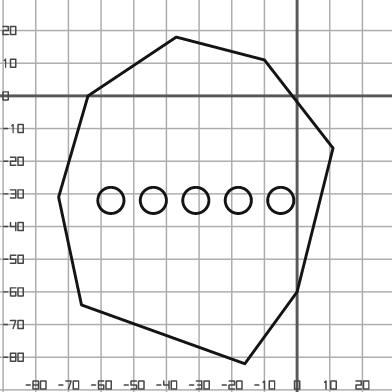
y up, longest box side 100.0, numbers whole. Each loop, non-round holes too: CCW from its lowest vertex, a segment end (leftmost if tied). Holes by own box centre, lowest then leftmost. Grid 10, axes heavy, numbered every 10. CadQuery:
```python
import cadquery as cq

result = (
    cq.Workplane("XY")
    .moveTo(-16.0, -82.0)
    .lineTo(0.0, -60.0)
    .lineTo(11.0, -16.0)
    .lineTo(-10.0, 11.0)
    .lineTo(-37.0, 18.0)
    .lineTo(-64.0, 0.0)
    .lineTo(-73.0, -31.0)
    .lineTo(-66.0, -64.0)
    .close()
    .moveTo(-57.0, -32.0)
    .circle(4.0)
    .moveTo(-44.0, -32.0)
    .circle(4.0)
    .moveTo(-31.0, -32.0)
    .circle(4.0)
    .moveTo(-18.0, -32.0)
    .circle(4.0)
    .moveTo(-5.0, -32.0)
    .circle(4.0)
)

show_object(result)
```